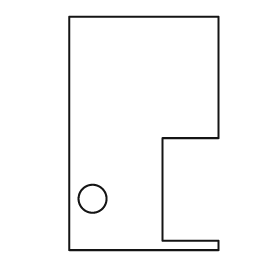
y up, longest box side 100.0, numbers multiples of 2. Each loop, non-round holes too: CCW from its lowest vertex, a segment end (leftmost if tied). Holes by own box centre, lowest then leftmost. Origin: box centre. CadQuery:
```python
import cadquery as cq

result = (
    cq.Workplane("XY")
    .moveTo(-32.0, -50.0)
    .lineTo(32.0, -50.0)
    .lineTo(32.0, -46.0)
    .lineTo(8.0, -46.0)
    .lineTo(8.0, -2.0)
    .lineTo(32.0, -2.0)
    .lineTo(32.0, 50.0)
    .lineTo(-32.0, 50.0)
    .close()
    .moveTo(-22.0, -28.0)
    .circle(6.0)
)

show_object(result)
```